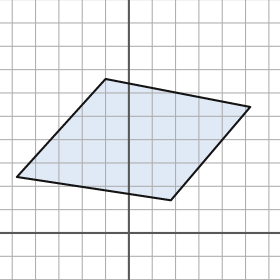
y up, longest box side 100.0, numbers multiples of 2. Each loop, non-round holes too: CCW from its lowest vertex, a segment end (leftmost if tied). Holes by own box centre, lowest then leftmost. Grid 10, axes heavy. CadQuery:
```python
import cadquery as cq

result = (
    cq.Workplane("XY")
    .moveTo(18.0, 14.0)
    .lineTo(52.0, 54.0)
    .lineTo(-10.0, 66.0)
    .lineTo(-48.0, 24.0)
    .close()
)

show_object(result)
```